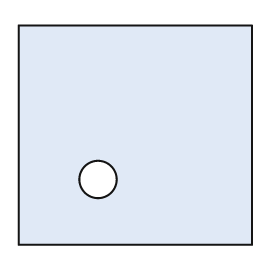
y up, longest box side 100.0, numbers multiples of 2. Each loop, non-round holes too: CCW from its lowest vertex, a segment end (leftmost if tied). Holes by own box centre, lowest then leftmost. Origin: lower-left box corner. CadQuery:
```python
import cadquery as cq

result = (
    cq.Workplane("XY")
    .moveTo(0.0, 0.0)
    .lineTo(100.0, 0.0)
    .lineTo(100.0, 94.0)
    .lineTo(0.0, 94.0)
    .close()
    .moveTo(34.0, 28.0)
    .circle(8.0)
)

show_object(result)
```